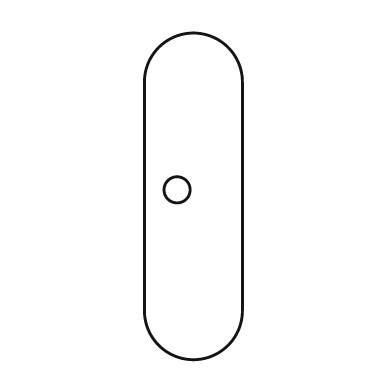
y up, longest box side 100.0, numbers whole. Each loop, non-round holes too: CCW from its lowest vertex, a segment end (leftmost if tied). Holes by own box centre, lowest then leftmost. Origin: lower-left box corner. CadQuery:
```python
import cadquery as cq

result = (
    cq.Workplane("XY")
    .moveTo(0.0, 15.0)
    .threePointArc((15.0, 0.0), (30.0, 15.0))
    .lineTo(30.0, 85.0)
    .threePointArc((15.0, 100.0), (0.0, 85.0))
    .close()
    .moveTo(10.0, 52.0)
    .circle(4.0)
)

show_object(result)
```